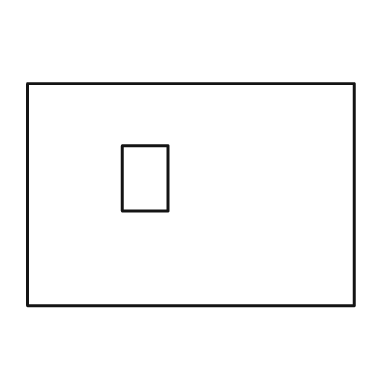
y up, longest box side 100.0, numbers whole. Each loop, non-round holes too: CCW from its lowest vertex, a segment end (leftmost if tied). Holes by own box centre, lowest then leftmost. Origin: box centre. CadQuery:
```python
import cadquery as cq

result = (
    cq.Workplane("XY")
    .moveTo(-50.0, -34.0)
    .lineTo(50.0, -34.0)
    .lineTo(50.0, 34.0)
    .lineTo(-50.0, 34.0)
    .close()
    .moveTo(-21.0, -5.0)
    .lineTo(-7.0, -5.0)
    .lineTo(-7.0, 15.0)
    .lineTo(-21.0, 15.0)
    .close()
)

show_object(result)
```